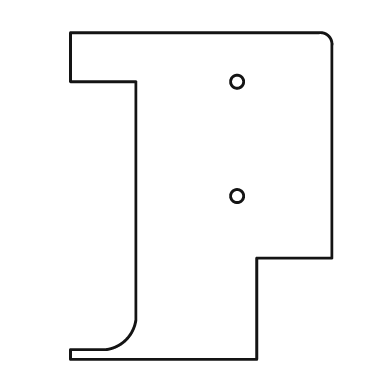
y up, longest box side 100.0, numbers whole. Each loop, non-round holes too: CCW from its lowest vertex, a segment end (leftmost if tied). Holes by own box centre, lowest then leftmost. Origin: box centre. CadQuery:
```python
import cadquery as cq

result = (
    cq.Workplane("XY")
    .moveTo(-40.0, -50.0)
    .lineTo(17.0, -50.0)
    .lineTo(17.0, -19.0)
    .lineTo(40.0, -19.0)
    .lineTo(40.0, 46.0)
    .threePointArc((39.0, 49.0), (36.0, 50.0))
    .lineTo(-40.0, 50.0)
    .lineTo(-40.0, 35.0)
    .lineTo(-20.0, 35.0)
    .lineTo(-20.0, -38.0)
    .threePointArc((-23.0, -44.0), (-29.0, -47.0))
    .lineTo(-40.0, -47.0)
    .close()
    .moveTo(11.0, 0.0)
    .circle(2.0)
    .moveTo(11.0, 35.0)
    .circle(2.0)
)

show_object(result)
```